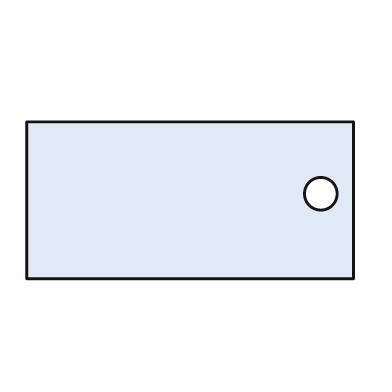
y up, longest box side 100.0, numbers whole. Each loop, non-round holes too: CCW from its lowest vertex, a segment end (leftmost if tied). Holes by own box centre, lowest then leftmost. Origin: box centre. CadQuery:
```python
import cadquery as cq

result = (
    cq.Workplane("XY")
    .moveTo(-50.0, -24.0)
    .lineTo(50.0, -24.0)
    .lineTo(50.0, 24.0)
    .lineTo(-50.0, 24.0)
    .close()
    .moveTo(40.0, 2.0)
    .circle(5.0)
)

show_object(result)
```